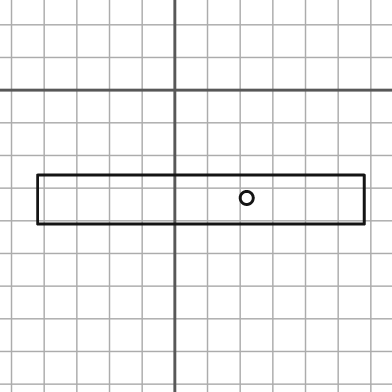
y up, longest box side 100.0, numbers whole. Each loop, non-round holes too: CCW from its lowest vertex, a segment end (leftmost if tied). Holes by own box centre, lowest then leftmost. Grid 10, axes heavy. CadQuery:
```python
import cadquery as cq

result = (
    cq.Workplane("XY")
    .moveTo(-42.0, -41.0)
    .lineTo(58.0, -41.0)
    .lineTo(58.0, -26.0)
    .lineTo(-42.0, -26.0)
    .close()
    .moveTo(22.0, -33.0)
    .circle(2.0)
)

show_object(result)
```